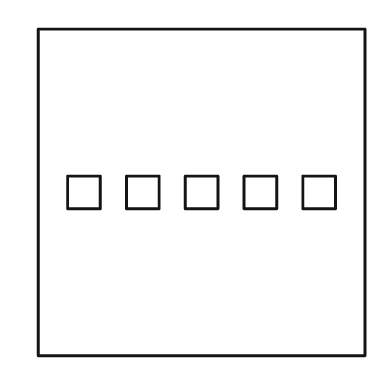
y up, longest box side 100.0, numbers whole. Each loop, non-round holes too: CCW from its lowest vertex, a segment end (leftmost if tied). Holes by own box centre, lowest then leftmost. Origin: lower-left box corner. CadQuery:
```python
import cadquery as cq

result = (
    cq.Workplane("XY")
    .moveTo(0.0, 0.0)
    .lineTo(100.0, 0.0)
    .lineTo(100.0, 100.0)
    .lineTo(0.0, 100.0)
    .close()
    .moveTo(9.0, 45.0)
    .lineTo(19.0, 45.0)
    .lineTo(19.0, 55.0)
    .lineTo(9.0, 55.0)
    .close()
    .moveTo(27.0, 45.0)
    .lineTo(37.0, 45.0)
    .lineTo(37.0, 55.0)
    .lineTo(27.0, 55.0)
    .close()
    .moveTo(45.0, 45.0)
    .lineTo(55.0, 45.0)
    .lineTo(55.0, 55.0)
    .lineTo(45.0, 55.0)
    .close()
    .moveTo(63.0, 45.0)
    .lineTo(73.0, 45.0)
    .lineTo(73.0, 55.0)
    .lineTo(63.0, 55.0)
    .close()
    .moveTo(81.0, 45.0)
    .lineTo(91.0, 45.0)
    .lineTo(91.0, 55.0)
    .lineTo(81.0, 55.0)
    .close()
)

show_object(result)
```